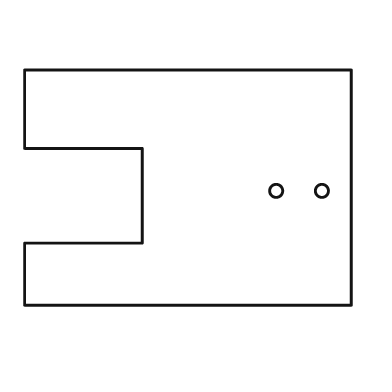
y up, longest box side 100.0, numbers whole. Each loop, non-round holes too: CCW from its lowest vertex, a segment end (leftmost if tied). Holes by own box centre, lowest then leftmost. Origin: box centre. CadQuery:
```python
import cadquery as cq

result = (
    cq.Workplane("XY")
    .moveTo(-50.0, -36.0)
    .lineTo(50.0, -36.0)
    .lineTo(50.0, 36.0)
    .lineTo(-50.0, 36.0)
    .lineTo(-50.0, 12.0)
    .lineTo(-14.0, 12.0)
    .lineTo(-14.0, -17.0)
    .lineTo(-50.0, -17.0)
    .close()
    .moveTo(27.0, -1.0)
    .circle(2.0)
    .moveTo(41.0, -1.0)
    .circle(2.0)
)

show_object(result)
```